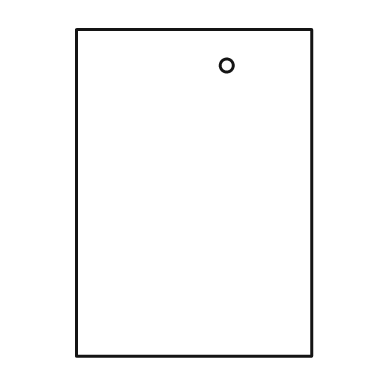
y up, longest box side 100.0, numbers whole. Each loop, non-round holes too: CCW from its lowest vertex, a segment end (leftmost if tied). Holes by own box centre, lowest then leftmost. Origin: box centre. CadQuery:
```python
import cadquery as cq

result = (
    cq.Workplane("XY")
    .moveTo(-36.0, -50.0)
    .lineTo(36.0, -50.0)
    .lineTo(36.0, 50.0)
    .lineTo(-36.0, 50.0)
    .close()
    .moveTo(10.0, 39.0)
    .circle(2.0)
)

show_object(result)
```